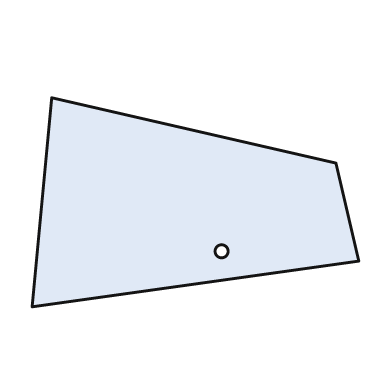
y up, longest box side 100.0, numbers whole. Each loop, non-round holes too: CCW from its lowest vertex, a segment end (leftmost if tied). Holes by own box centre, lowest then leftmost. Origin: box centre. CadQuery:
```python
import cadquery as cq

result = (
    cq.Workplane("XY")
    .moveTo(-50.0, -32.0)
    .lineTo(50.0, -18.0)
    .lineTo(43.0, 12.0)
    .lineTo(-44.0, 32.0)
    .close()
    .moveTo(8.0, -15.0)
    .circle(2.0)
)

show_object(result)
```